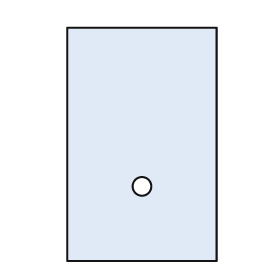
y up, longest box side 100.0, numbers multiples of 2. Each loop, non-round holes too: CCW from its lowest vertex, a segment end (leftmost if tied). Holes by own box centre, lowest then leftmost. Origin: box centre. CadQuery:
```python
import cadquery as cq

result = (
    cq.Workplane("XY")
    .moveTo(-32.0, -50.0)
    .lineTo(32.0, -50.0)
    .lineTo(32.0, 50.0)
    .lineTo(-32.0, 50.0)
    .close()
    .moveTo(0.0, -18.0)
    .circle(4.0)
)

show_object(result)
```